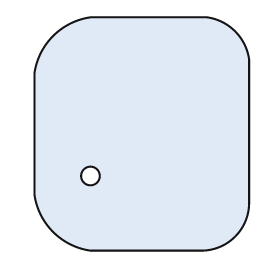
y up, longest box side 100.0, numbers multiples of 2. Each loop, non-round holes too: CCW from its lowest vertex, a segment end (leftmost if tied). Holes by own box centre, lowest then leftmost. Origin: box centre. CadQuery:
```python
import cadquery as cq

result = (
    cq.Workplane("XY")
    .moveTo(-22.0, -50.0)
    .lineTo(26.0, -50.0)
    .threePointArc((40.0, -44.0), (46.0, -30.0))
    .lineTo(46.0, 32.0)
    .threePointArc((40.0, 44.0), (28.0, 50.0))
    .lineTo(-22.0, 50.0)
    .threePointArc((-38.0, 42.0), (-46.0, 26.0))
    .lineTo(-46.0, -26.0)
    .threePointArc((-38.0, -42.0), (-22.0, -50.0))
    .close()
    .moveTo(-22.0, -18.0)
    .circle(4.0)
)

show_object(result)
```